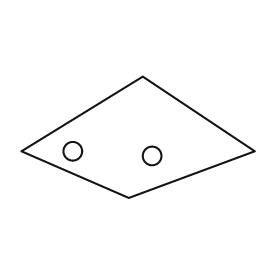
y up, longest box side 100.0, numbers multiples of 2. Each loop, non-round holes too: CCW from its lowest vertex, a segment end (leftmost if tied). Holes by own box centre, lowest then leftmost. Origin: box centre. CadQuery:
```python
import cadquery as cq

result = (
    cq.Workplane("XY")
    .moveTo(-4.0, -26.0)
    .lineTo(50.0, -6.0)
    .lineTo(2.0, 26.0)
    .lineTo(-50.0, -6.0)
    .close()
    .moveTo(6.0, -8.0)
    .circle(4.0)
    .moveTo(-28.0, -6.0)
    .circle(4.0)
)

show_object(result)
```